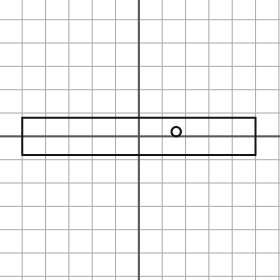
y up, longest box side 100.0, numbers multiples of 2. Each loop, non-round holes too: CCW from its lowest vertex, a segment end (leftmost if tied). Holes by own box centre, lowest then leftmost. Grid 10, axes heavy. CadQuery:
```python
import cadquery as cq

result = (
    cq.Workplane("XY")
    .moveTo(-50.0, -8.0)
    .lineTo(50.0, -8.0)
    .lineTo(50.0, 8.0)
    .lineTo(-50.0, 8.0)
    .close()
    .moveTo(16.0, 2.0)
    .circle(2.0)
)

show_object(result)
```